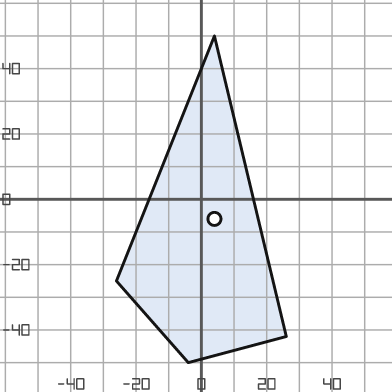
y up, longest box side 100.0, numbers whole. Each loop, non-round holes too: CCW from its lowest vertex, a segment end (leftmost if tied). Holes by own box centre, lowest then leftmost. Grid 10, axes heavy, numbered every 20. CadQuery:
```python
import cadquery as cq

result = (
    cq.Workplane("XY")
    .moveTo(-4.0, -50.0)
    .lineTo(26.0, -42.0)
    .lineTo(4.0, 50.0)
    .lineTo(-26.0, -25.0)
    .close()
    .moveTo(4.0, -6.0)
    .circle(2.0)
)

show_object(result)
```